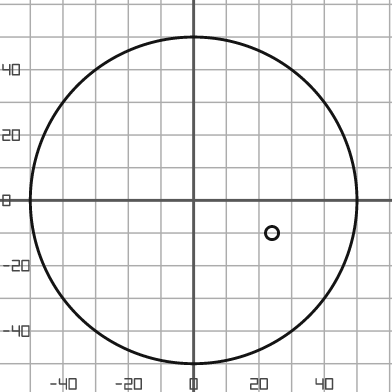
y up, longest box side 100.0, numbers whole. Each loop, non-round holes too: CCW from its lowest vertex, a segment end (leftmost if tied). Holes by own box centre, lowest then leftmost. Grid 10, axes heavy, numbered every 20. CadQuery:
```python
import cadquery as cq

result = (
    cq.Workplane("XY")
    .moveTo(0.0, 0.0)
    .circle(50.0)
    .moveTo(24.0, -10.0)
    .circle(2.0)
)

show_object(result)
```